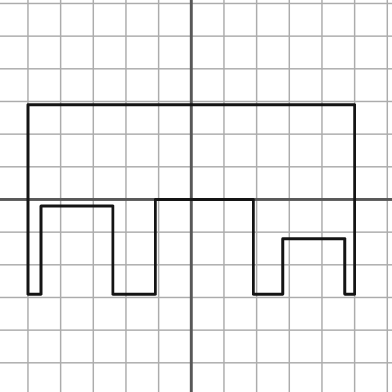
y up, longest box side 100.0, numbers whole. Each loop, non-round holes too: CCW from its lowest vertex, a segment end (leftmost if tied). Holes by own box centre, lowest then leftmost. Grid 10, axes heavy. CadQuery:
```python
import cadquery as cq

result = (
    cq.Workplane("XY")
    .moveTo(-50.0, -29.0)
    .lineTo(-46.0, -29.0)
    .lineTo(-46.0, -2.0)
    .lineTo(-24.0, -2.0)
    .lineTo(-24.0, -29.0)
    .lineTo(-11.0, -29.0)
    .lineTo(-11.0, 0.0)
    .lineTo(19.0, 0.0)
    .lineTo(19.0, -29.0)
    .lineTo(28.0, -29.0)
    .lineTo(28.0, -12.0)
    .lineTo(47.0, -12.0)
    .lineTo(47.0, -29.0)
    .lineTo(50.0, -29.0)
    .lineTo(50.0, 29.0)
    .lineTo(-50.0, 29.0)
    .close()
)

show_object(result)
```